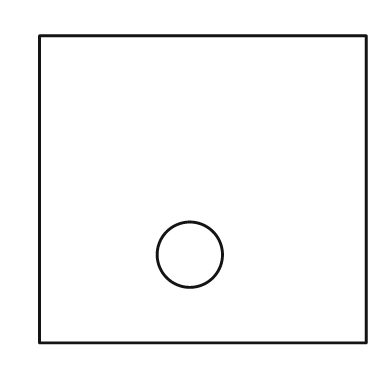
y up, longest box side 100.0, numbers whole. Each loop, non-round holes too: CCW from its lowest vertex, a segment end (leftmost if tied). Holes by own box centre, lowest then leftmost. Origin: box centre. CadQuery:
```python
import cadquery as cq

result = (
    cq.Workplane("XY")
    .moveTo(-50.0, -47.0)
    .lineTo(50.0, -47.0)
    .lineTo(50.0, 47.0)
    .lineTo(-50.0, 47.0)
    .close()
    .moveTo(-4.0, -20.0)
    .circle(10.0)
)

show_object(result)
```